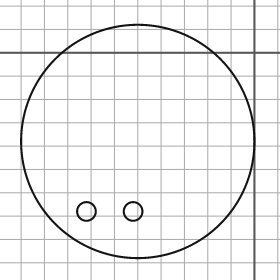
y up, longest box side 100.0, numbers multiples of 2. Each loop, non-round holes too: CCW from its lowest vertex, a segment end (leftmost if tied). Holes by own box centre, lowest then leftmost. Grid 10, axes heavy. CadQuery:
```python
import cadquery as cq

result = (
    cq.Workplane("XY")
    .moveTo(-50.0, -38.0)
    .circle(50.0)
    .moveTo(-72.0, -68.0)
    .circle(4.0)
    .moveTo(-52.0, -68.0)
    .circle(4.0)
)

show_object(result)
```